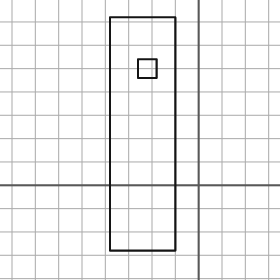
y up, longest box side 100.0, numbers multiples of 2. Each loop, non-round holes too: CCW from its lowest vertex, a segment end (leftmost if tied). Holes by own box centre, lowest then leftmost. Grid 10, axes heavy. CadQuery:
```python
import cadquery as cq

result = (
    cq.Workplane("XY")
    .moveTo(-38.0, -28.0)
    .lineTo(-10.0, -28.0)
    .lineTo(-10.0, 72.0)
    .lineTo(-38.0, 72.0)
    .close()
    .moveTo(-26.0, 46.0)
    .lineTo(-18.0, 46.0)
    .lineTo(-18.0, 54.0)
    .lineTo(-26.0, 54.0)
    .close()
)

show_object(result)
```